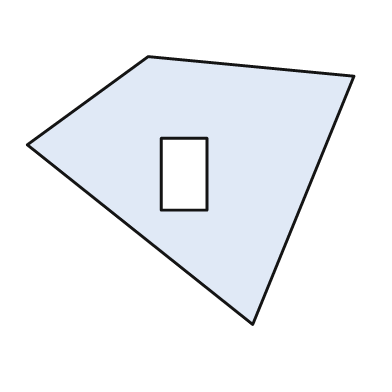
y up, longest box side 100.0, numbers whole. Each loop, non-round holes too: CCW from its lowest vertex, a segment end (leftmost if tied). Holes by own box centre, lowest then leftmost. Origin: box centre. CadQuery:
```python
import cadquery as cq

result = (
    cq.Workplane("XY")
    .moveTo(19.0, -41.0)
    .lineTo(50.0, 35.0)
    .lineTo(-13.0, 41.0)
    .lineTo(-50.0, 14.0)
    .close()
    .moveTo(-9.0, -6.0)
    .lineTo(5.0, -6.0)
    .lineTo(5.0, 16.0)
    .lineTo(-9.0, 16.0)
    .close()
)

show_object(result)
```